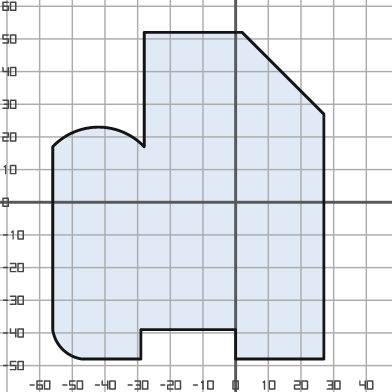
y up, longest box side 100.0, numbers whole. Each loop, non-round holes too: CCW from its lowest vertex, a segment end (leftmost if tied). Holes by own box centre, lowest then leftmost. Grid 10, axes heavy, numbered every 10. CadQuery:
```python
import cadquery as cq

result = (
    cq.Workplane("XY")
    .moveTo(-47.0, -48.0)
    .lineTo(-29.0, -48.0)
    .lineTo(-29.0, -39.0)
    .lineTo(0.0, -39.0)
    .lineTo(0.0, -48.0)
    .lineTo(27.0, -48.0)
    .lineTo(27.0, 27.0)
    .lineTo(2.0, 52.0)
    .lineTo(-28.0, 52.0)
    .lineTo(-28.0, 17.0)
    .threePointArc((-42.0, 23.0), (-56.0, 17.0))
    .lineTo(-56.0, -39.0)
    .threePointArc((-53.0, -45.0), (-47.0, -48.0))
    .close()
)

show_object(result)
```